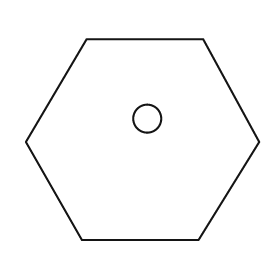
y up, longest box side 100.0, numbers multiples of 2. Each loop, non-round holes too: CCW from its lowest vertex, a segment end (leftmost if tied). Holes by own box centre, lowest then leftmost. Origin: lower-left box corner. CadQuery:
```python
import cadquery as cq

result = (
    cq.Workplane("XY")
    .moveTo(24.0, 0.0)
    .lineTo(74.0, 0.0)
    .lineTo(100.0, 42.0)
    .lineTo(76.0, 86.0)
    .lineTo(26.0, 86.0)
    .lineTo(0.0, 42.0)
    .close()
    .moveTo(52.0, 52.0)
    .circle(6.0)
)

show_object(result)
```